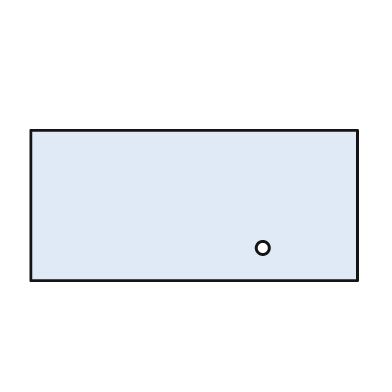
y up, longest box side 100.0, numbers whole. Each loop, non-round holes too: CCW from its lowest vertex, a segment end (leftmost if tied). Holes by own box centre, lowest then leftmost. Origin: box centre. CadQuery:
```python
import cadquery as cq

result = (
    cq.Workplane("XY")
    .moveTo(-50.0, -23.0)
    .lineTo(50.0, -23.0)
    .lineTo(50.0, 23.0)
    .lineTo(-50.0, 23.0)
    .close()
    .moveTo(21.0, -13.0)
    .circle(2.0)
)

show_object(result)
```